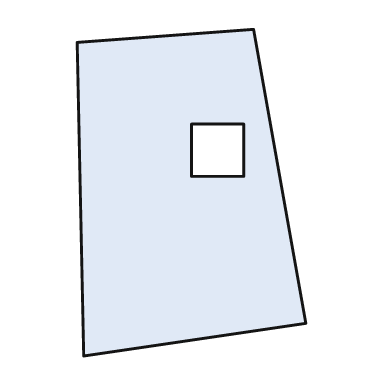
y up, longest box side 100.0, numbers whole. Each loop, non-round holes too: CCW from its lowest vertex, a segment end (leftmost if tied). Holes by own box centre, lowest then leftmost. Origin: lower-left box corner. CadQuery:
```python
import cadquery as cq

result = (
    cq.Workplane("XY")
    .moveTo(2.0, 0.0)
    .lineTo(70.0, 10.0)
    .lineTo(54.0, 100.0)
    .lineTo(0.0, 96.0)
    .close()
    .moveTo(35.0, 55.0)
    .lineTo(51.0, 55.0)
    .lineTo(51.0, 71.0)
    .lineTo(35.0, 71.0)
    .close()
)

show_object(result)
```